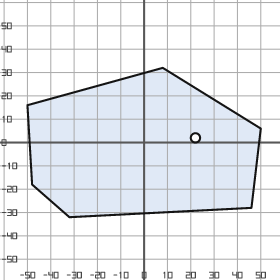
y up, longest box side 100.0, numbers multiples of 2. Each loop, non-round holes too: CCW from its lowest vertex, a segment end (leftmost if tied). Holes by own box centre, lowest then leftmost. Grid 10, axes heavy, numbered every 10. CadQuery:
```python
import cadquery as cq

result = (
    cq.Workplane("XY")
    .moveTo(-32.0, -32.0)
    .lineTo(46.0, -28.0)
    .lineTo(50.0, 6.0)
    .lineTo(8.0, 32.0)
    .lineTo(-50.0, 16.0)
    .lineTo(-48.0, -18.0)
    .close()
    .moveTo(22.0, 2.0)
    .circle(2.0)
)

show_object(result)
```